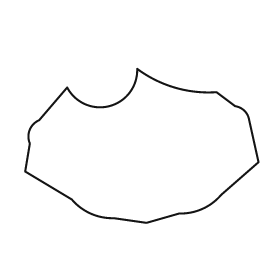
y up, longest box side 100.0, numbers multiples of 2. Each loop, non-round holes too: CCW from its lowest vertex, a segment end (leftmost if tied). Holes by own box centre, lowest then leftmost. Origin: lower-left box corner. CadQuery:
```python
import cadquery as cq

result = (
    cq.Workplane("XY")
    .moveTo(52.0, 0.0)
    .lineTo(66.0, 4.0)
    .threePointArc((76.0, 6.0), (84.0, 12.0))
    .lineTo(100.0, 26.0)
    .lineTo(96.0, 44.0)
    .threePointArc((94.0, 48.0), (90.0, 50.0))
    .lineTo(82.0, 56.0)
    .threePointArc((64.0, 58.0), (48.0, 66.0))
    .threePointArc((36.0, 50.0), (18.0, 58.0))
    .lineTo(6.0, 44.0)
    .threePointArc((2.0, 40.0), (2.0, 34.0))
    .lineTo(0.0, 22.0)
    .lineTo(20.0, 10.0)
    .threePointArc((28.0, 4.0), (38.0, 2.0))
    .close()
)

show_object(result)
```